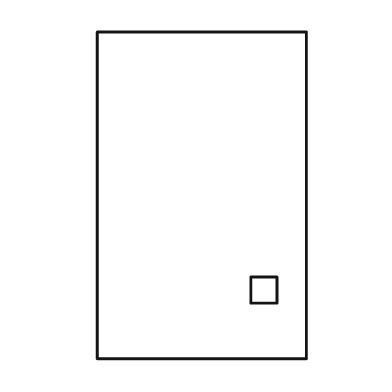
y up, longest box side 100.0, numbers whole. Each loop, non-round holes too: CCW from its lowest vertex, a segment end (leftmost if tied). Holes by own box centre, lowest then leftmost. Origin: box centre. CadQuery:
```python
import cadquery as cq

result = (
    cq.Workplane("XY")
    .moveTo(-32.0, -50.0)
    .lineTo(32.0, -50.0)
    .lineTo(32.0, 50.0)
    .lineTo(-32.0, 50.0)
    .close()
    .moveTo(15.0, -33.0)
    .lineTo(23.0, -33.0)
    .lineTo(23.0, -25.0)
    .lineTo(15.0, -25.0)
    .close()
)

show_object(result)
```